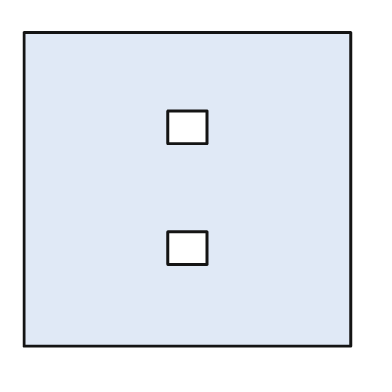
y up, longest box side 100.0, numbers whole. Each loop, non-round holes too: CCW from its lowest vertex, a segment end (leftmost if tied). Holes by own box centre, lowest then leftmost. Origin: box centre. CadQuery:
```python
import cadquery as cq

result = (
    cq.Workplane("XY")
    .moveTo(-50.0, -48.0)
    .lineTo(50.0, -48.0)
    .lineTo(50.0, 48.0)
    .lineTo(-50.0, 48.0)
    .close()
    .moveTo(-6.0, -23.0)
    .lineTo(6.0, -23.0)
    .lineTo(6.0, -13.0)
    .lineTo(-6.0, -13.0)
    .close()
    .moveTo(-6.0, 14.0)
    .lineTo(6.0, 14.0)
    .lineTo(6.0, 24.0)
    .lineTo(-6.0, 24.0)
    .close()
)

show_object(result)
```